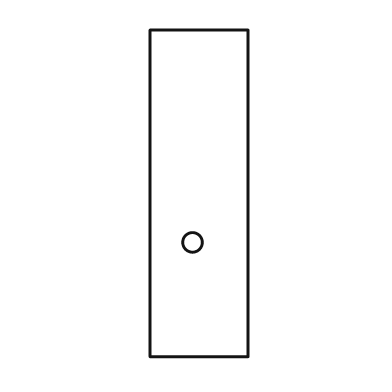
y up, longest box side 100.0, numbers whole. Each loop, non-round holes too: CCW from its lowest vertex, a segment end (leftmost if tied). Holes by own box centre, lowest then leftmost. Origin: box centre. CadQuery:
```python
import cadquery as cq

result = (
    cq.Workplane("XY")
    .moveTo(-15.0, -50.0)
    .lineTo(15.0, -50.0)
    .lineTo(15.0, 50.0)
    .lineTo(-15.0, 50.0)
    .close()
    .moveTo(-2.0, -15.0)
    .circle(3.0)
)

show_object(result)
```